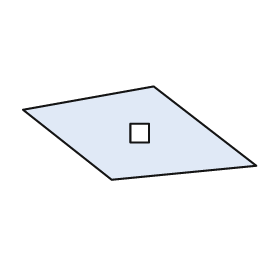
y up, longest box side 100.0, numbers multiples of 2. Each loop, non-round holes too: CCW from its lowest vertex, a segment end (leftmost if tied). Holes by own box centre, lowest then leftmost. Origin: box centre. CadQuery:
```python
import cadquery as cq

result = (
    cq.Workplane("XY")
    .moveTo(-12.0, -20.0)
    .lineTo(50.0, -14.0)
    .lineTo(6.0, 20.0)
    .lineTo(-50.0, 10.0)
    .close()
    .moveTo(-4.0, -4.0)
    .lineTo(4.0, -4.0)
    .lineTo(4.0, 4.0)
    .lineTo(-4.0, 4.0)
    .close()
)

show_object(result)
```